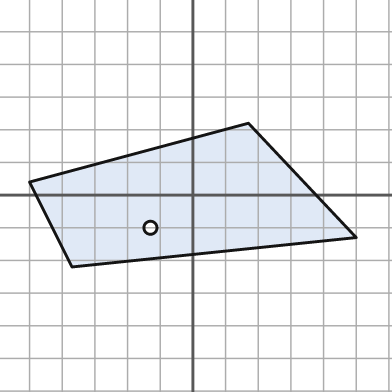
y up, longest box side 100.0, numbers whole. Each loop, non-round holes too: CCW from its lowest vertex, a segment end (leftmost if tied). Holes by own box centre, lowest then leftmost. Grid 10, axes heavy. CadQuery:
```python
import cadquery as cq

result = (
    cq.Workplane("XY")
    .moveTo(-37.0, -22.0)
    .lineTo(50.0, -13.0)
    .lineTo(17.0, 22.0)
    .lineTo(-50.0, 4.0)
    .close()
    .moveTo(-13.0, -10.0)
    .circle(2.0)
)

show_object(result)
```